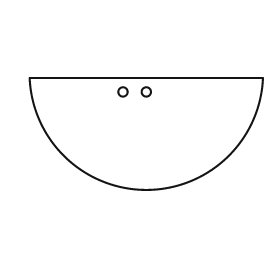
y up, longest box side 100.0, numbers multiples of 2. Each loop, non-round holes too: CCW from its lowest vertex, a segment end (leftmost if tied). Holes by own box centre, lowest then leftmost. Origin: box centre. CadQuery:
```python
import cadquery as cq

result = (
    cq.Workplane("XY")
    .moveTo(-50.0, 24.0)
    .threePointArc((0.0, -24.0), (50.0, 24.0))
    .close()
    .moveTo(-10.0, 18.0)
    .circle(2.0)
    .moveTo(0.0, 18.0)
    .circle(2.0)
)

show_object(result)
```